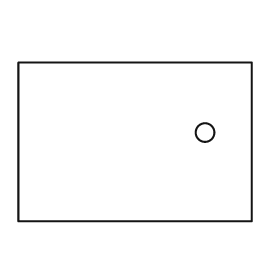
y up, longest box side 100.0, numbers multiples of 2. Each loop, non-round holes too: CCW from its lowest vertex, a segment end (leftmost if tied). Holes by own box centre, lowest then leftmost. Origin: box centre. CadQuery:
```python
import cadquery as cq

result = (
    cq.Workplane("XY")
    .moveTo(-50.0, -34.0)
    .lineTo(50.0, -34.0)
    .lineTo(50.0, 34.0)
    .lineTo(-50.0, 34.0)
    .close()
    .moveTo(30.0, 4.0)
    .circle(4.0)
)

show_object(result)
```